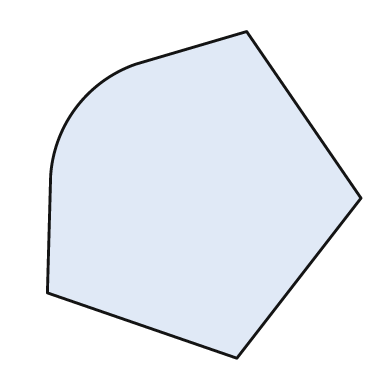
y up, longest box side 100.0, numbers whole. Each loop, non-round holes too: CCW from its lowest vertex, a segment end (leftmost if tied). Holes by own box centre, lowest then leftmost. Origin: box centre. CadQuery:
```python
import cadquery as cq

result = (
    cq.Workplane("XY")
    .moveTo(10.0, -50.0)
    .lineTo(48.0, -1.0)
    .lineTo(13.0, 50.0)
    .lineTo(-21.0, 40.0)
    .threePointArc((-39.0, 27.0), (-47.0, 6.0))
    .lineTo(-48.0, -30.0)
    .close()
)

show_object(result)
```